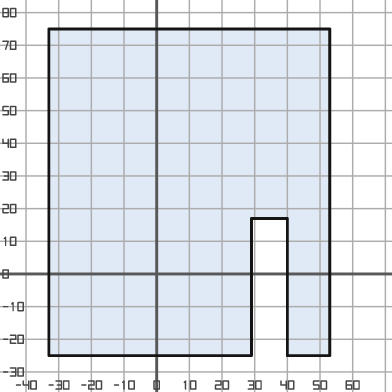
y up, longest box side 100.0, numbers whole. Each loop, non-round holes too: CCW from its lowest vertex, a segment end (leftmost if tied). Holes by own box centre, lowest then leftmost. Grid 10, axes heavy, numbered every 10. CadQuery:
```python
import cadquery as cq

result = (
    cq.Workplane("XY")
    .moveTo(-33.0, -25.0)
    .lineTo(29.0, -25.0)
    .lineTo(29.0, 17.0)
    .lineTo(40.0, 17.0)
    .lineTo(40.0, -25.0)
    .lineTo(53.0, -25.0)
    .lineTo(53.0, 75.0)
    .lineTo(-33.0, 75.0)
    .close()
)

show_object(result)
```